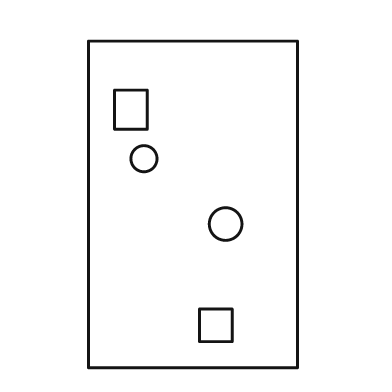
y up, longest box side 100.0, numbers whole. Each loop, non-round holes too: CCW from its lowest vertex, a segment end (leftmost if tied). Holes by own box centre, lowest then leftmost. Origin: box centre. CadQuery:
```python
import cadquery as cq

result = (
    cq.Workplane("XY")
    .moveTo(-32.0, -50.0)
    .lineTo(32.0, -50.0)
    .lineTo(32.0, 50.0)
    .lineTo(-32.0, 50.0)
    .close()
    .moveTo(2.0, -42.0)
    .lineTo(12.0, -42.0)
    .lineTo(12.0, -32.0)
    .lineTo(2.0, -32.0)
    .close()
    .moveTo(10.0, -6.0)
    .circle(5.0)
    .moveTo(-15.0, 14.0)
    .circle(4.0)
    .moveTo(-24.0, 23.0)
    .lineTo(-14.0, 23.0)
    .lineTo(-14.0, 35.0)
    .lineTo(-24.0, 35.0)
    .close()
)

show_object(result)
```